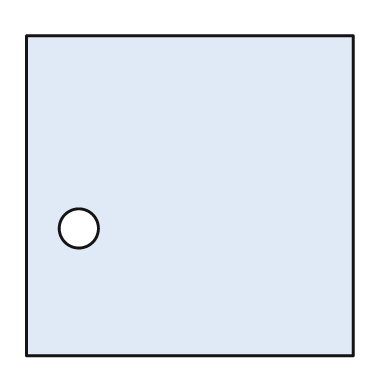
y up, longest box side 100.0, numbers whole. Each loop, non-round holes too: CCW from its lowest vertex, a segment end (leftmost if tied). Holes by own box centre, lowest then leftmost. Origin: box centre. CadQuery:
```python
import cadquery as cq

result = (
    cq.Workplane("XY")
    .moveTo(-50.0, -49.0)
    .lineTo(50.0, -49.0)
    .lineTo(50.0, 49.0)
    .lineTo(-50.0, 49.0)
    .close()
    .moveTo(-34.0, -10.0)
    .circle(6.0)
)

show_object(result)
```